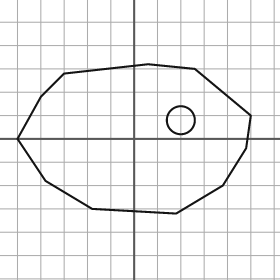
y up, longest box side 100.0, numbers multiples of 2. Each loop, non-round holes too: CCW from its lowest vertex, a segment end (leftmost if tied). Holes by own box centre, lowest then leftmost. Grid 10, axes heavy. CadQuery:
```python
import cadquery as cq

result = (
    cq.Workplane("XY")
    .moveTo(18.0, -32.0)
    .lineTo(38.0, -20.0)
    .lineTo(48.0, -4.0)
    .lineTo(50.0, 10.0)
    .lineTo(26.0, 30.0)
    .lineTo(6.0, 32.0)
    .lineTo(-30.0, 28.0)
    .lineTo(-40.0, 18.0)
    .lineTo(-50.0, 0.0)
    .lineTo(-38.0, -18.0)
    .lineTo(-18.0, -30.0)
    .close()
    .moveTo(20.0, 8.0)
    .circle(6.0)
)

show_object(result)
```